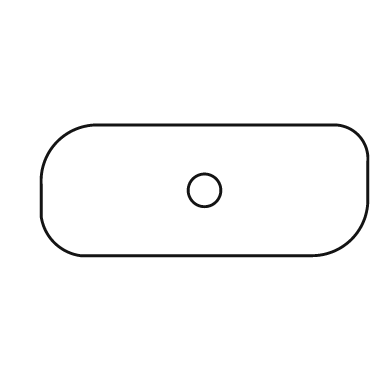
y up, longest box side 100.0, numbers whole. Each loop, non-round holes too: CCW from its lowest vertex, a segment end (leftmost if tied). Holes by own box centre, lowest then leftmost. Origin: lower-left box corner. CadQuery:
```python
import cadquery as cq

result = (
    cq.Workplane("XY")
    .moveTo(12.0, 0.0)
    .lineTo(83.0, 0.0)
    .threePointArc((95.0, 5.0), (100.0, 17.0))
    .lineTo(100.0, 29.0)
    .threePointArc((97.0, 37.0), (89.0, 40.0))
    .lineTo(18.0, 40.0)
    .threePointArc((5.0, 35.0), (0.0, 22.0))
    .lineTo(0.0, 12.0)
    .threePointArc((4.0, 4.0), (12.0, 0.0))
    .close()
    .moveTo(50.0, 20.0)
    .circle(5.0)
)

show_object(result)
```